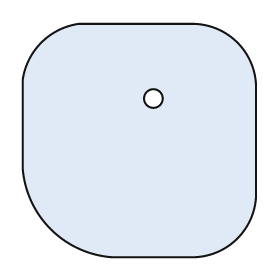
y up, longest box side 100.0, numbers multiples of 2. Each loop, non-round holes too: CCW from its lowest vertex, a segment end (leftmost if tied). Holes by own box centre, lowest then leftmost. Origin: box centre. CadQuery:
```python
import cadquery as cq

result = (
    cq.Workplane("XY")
    .moveTo(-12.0, -50.0)
    .lineTo(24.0, -50.0)
    .threePointArc((42.0, -42.0), (50.0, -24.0))
    .lineTo(50.0, 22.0)
    .threePointArc((42.0, 42.0), (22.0, 50.0))
    .lineTo(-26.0, 50.0)
    .threePointArc((-42.0, 42.0), (-50.0, 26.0))
    .lineTo(-50.0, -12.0)
    .threePointArc((-38.0, -38.0), (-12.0, -50.0))
    .close()
    .moveTo(6.0, 18.0)
    .circle(4.0)
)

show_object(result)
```